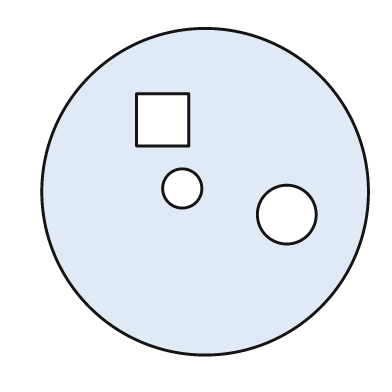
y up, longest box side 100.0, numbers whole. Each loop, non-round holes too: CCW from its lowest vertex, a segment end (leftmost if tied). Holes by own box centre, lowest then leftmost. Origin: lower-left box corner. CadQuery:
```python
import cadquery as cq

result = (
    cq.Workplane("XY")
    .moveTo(50.0, 50.0)
    .circle(50.0)
    .moveTo(75.0, 43.0)
    .circle(9.0)
    .moveTo(43.0, 51.0)
    .circle(6.0)
    .moveTo(29.0, 64.0)
    .lineTo(45.0, 64.0)
    .lineTo(45.0, 80.0)
    .lineTo(29.0, 80.0)
    .close()
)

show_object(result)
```